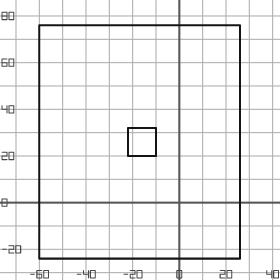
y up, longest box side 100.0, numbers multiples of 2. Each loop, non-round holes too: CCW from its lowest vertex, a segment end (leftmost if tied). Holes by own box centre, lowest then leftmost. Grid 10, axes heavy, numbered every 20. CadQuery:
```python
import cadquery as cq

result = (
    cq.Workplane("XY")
    .moveTo(-60.0, -24.0)
    .lineTo(26.0, -24.0)
    .lineTo(26.0, 76.0)
    .lineTo(-60.0, 76.0)
    .close()
    .moveTo(-22.0, 20.0)
    .lineTo(-10.0, 20.0)
    .lineTo(-10.0, 32.0)
    .lineTo(-22.0, 32.0)
    .close()
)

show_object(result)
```